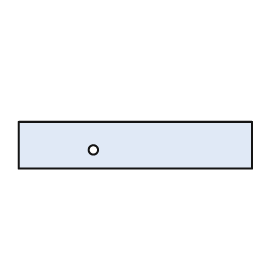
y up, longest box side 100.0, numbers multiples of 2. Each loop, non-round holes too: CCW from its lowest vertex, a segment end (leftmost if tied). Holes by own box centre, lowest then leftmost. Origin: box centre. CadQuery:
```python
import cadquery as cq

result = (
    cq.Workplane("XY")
    .moveTo(-50.0, -10.0)
    .lineTo(50.0, -10.0)
    .lineTo(50.0, 10.0)
    .lineTo(-50.0, 10.0)
    .close()
    .moveTo(-18.0, -2.0)
    .circle(2.0)
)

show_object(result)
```